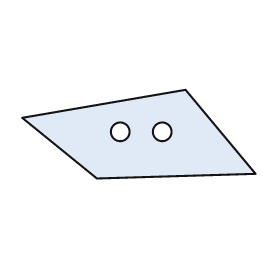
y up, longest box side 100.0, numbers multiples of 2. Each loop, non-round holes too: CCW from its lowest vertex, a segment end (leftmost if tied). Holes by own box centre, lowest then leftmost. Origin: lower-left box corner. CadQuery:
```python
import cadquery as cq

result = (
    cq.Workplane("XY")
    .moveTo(32.0, 0.0)
    .lineTo(100.0, 2.0)
    .lineTo(70.0, 38.0)
    .lineTo(0.0, 26.0)
    .close()
    .moveTo(42.0, 20.0)
    .circle(4.0)
    .moveTo(60.0, 20.0)
    .circle(4.0)
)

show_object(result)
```